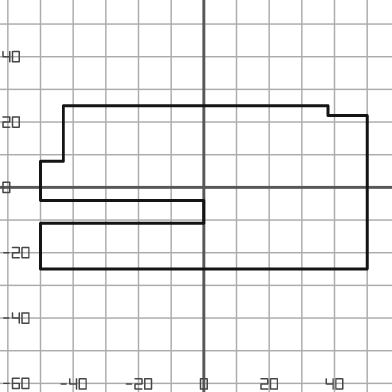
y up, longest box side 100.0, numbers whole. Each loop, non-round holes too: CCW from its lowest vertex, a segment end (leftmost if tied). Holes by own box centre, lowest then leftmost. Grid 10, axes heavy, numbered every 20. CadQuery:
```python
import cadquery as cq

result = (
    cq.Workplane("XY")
    .moveTo(-50.0, -25.0)
    .lineTo(50.0, -25.0)
    .lineTo(50.0, 22.0)
    .lineTo(38.0, 22.0)
    .lineTo(38.0, 25.0)
    .lineTo(-43.0, 25.0)
    .lineTo(-43.0, 8.0)
    .lineTo(-50.0, 8.0)
    .lineTo(-50.0, -4.0)
    .lineTo(0.0, -4.0)
    .lineTo(0.0, -11.0)
    .lineTo(-50.0, -11.0)
    .close()
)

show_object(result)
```